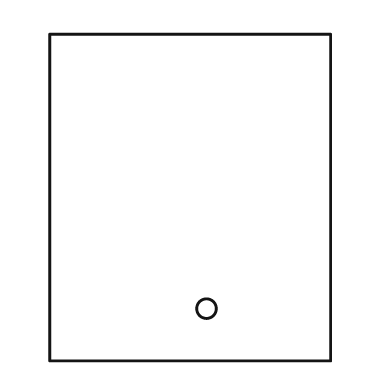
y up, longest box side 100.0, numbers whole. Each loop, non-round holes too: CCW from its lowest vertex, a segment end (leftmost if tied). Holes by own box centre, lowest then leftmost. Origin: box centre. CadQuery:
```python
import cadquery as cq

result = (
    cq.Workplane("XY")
    .moveTo(-43.0, -50.0)
    .lineTo(43.0, -50.0)
    .lineTo(43.0, 50.0)
    .lineTo(-43.0, 50.0)
    .close()
    .moveTo(5.0, -34.0)
    .circle(3.0)
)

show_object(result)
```